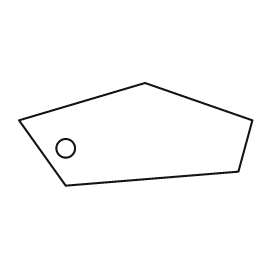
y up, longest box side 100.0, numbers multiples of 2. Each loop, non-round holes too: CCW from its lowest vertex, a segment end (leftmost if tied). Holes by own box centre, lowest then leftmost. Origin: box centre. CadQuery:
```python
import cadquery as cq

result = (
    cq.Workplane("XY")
    .moveTo(-30.0, -22.0)
    .lineTo(44.0, -16.0)
    .lineTo(50.0, 6.0)
    .lineTo(4.0, 22.0)
    .lineTo(-50.0, 6.0)
    .close()
    .moveTo(-30.0, -6.0)
    .circle(4.0)
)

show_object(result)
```